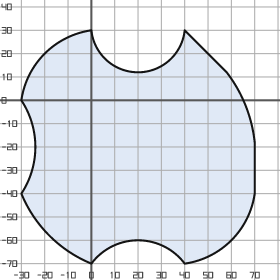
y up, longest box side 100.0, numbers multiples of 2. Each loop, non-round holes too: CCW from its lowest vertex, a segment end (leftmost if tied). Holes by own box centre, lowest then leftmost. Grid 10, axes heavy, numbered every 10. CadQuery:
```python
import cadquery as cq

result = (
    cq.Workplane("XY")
    .moveTo(0.0, -70.0)
    .threePointArc((20.0, -60.0), (40.0, -70.0))
    .threePointArc((60.0, -60.0), (70.0, -40.0))
    .lineTo(70.0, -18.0)
    .threePointArc((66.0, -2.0), (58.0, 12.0))
    .lineTo(40.0, 30.0)
    .threePointArc((20.0, 12.0), (0.0, 30.0))
    .threePointArc((-20.0, 20.0), (-30.0, 0.0))
    .threePointArc((-24.0, -20.0), (-30.0, -40.0))
    .threePointArc((-18.0, -58.0), (0.0, -70.0))
    .close()
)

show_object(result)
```